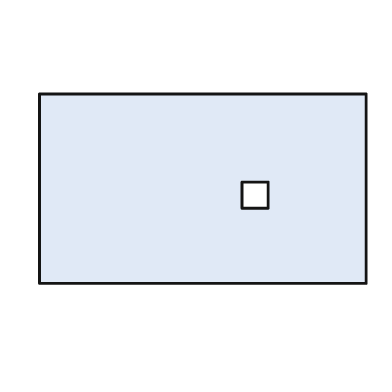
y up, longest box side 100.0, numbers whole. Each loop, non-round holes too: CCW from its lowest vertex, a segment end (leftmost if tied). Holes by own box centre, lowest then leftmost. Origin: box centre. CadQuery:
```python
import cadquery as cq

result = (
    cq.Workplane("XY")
    .moveTo(-50.0, -29.0)
    .lineTo(50.0, -29.0)
    .lineTo(50.0, 29.0)
    .lineTo(-50.0, 29.0)
    .close()
    .moveTo(12.0, -6.0)
    .lineTo(20.0, -6.0)
    .lineTo(20.0, 2.0)
    .lineTo(12.0, 2.0)
    .close()
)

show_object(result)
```